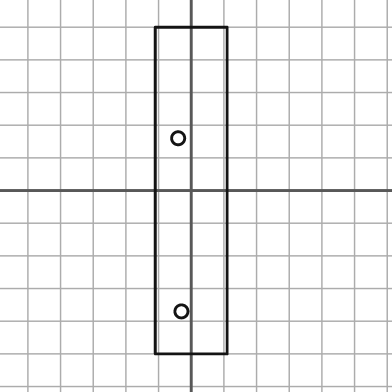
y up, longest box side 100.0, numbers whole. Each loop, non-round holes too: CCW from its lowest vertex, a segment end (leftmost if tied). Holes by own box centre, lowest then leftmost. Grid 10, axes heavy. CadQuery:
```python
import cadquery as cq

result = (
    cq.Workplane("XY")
    .moveTo(-11.0, -50.0)
    .lineTo(11.0, -50.0)
    .lineTo(11.0, 50.0)
    .lineTo(-11.0, 50.0)
    .close()
    .moveTo(-3.0, -37.0)
    .circle(2.0)
    .moveTo(-4.0, 16.0)
    .circle(2.0)
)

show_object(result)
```